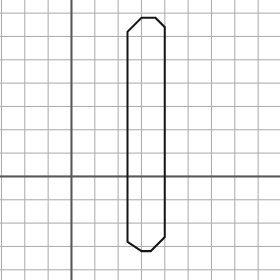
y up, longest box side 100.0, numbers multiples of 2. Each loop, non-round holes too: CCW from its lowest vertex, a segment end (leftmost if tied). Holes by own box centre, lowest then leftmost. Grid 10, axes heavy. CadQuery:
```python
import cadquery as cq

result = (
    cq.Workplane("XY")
    .moveTo(30.0, -32.0)
    .lineTo(34.0, -32.0)
    .lineTo(40.0, -26.0)
    .lineTo(40.0, 64.0)
    .lineTo(36.0, 68.0)
    .lineTo(30.0, 68.0)
    .lineTo(24.0, 62.0)
    .lineTo(24.0, -28.0)
    .close()
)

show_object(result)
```